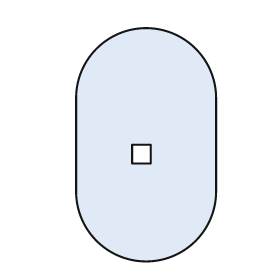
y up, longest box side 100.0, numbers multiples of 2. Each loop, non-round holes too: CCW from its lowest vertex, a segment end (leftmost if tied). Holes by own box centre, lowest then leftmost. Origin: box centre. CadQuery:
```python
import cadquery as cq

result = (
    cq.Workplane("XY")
    .moveTo(-30.0, -20.0)
    .threePointArc((0.0, -50.0), (30.0, -20.0))
    .lineTo(30.0, 20.0)
    .threePointArc((0.0, 50.0), (-30.0, 20.0))
    .close()
    .moveTo(-6.0, -8.0)
    .lineTo(2.0, -8.0)
    .lineTo(2.0, 0.0)
    .lineTo(-6.0, 0.0)
    .close()
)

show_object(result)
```